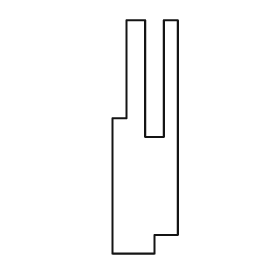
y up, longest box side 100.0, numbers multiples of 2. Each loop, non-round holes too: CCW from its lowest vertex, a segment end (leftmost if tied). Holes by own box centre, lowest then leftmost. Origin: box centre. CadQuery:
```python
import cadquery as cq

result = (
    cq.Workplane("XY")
    .moveTo(-14.0, -50.0)
    .lineTo(4.0, -50.0)
    .lineTo(4.0, -42.0)
    .lineTo(14.0, -42.0)
    .lineTo(14.0, 50.0)
    .lineTo(8.0, 50.0)
    .lineTo(8.0, 0.0)
    .lineTo(0.0, 0.0)
    .lineTo(0.0, 50.0)
    .lineTo(-8.0, 50.0)
    .lineTo(-8.0, 8.0)
    .lineTo(-14.0, 8.0)
    .close()
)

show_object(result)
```